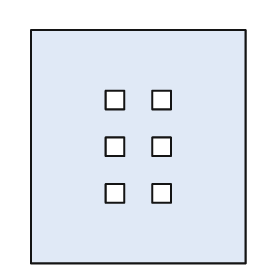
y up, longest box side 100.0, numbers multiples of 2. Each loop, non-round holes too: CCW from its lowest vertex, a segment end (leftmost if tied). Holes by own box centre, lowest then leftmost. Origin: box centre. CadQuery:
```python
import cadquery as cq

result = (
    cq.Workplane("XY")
    .moveTo(-46.0, -50.0)
    .lineTo(46.0, -50.0)
    .lineTo(46.0, 50.0)
    .lineTo(-46.0, 50.0)
    .close()
    .moveTo(-14.0, -24.0)
    .lineTo(-6.0, -24.0)
    .lineTo(-6.0, -16.0)
    .lineTo(-14.0, -16.0)
    .close()
    .moveTo(6.0, -24.0)
    .lineTo(14.0, -24.0)
    .lineTo(14.0, -16.0)
    .lineTo(6.0, -16.0)
    .close()
    .moveTo(-14.0, -4.0)
    .lineTo(-6.0, -4.0)
    .lineTo(-6.0, 4.0)
    .lineTo(-14.0, 4.0)
    .close()
    .moveTo(6.0, -4.0)
    .lineTo(14.0, -4.0)
    .lineTo(14.0, 4.0)
    .lineTo(6.0, 4.0)
    .close()
    .moveTo(-14.0, 16.0)
    .lineTo(-6.0, 16.0)
    .lineTo(-6.0, 24.0)
    .lineTo(-14.0, 24.0)
    .close()
    .moveTo(6.0, 16.0)
    .lineTo(14.0, 16.0)
    .lineTo(14.0, 24.0)
    .lineTo(6.0, 24.0)
    .close()
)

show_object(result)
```